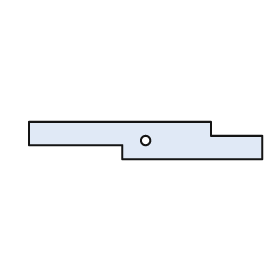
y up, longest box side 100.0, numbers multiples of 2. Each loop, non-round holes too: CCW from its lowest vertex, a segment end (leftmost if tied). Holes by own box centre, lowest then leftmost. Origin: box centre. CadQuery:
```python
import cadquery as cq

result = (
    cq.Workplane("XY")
    .moveTo(-10.0, -8.0)
    .lineTo(50.0, -8.0)
    .lineTo(50.0, 2.0)
    .lineTo(28.0, 2.0)
    .lineTo(28.0, 8.0)
    .lineTo(-50.0, 8.0)
    .lineTo(-50.0, -2.0)
    .lineTo(-10.0, -2.0)
    .close()
    .moveTo(0.0, 0.0)
    .circle(2.0)
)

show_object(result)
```